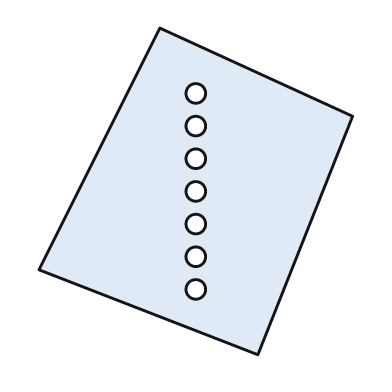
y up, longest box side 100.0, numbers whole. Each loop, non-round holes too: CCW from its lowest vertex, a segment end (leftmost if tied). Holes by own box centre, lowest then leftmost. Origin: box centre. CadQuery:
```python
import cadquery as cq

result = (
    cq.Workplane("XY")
    .moveTo(19.0, -50.0)
    .lineTo(48.0, 23.0)
    .lineTo(-11.0, 50.0)
    .lineTo(-48.0, -24.0)
    .close()
    .moveTo(0.0, -30.0)
    .circle(3.0)
    .moveTo(0.0, -20.0)
    .circle(3.0)
    .moveTo(0.0, -10.0)
    .circle(3.0)
    .moveTo(0.0, 0.0)
    .circle(3.0)
    .moveTo(0.0, 10.0)
    .circle(3.0)
    .moveTo(0.0, 20.0)
    .circle(3.0)
    .moveTo(0.0, 30.0)
    .circle(3.0)
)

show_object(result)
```